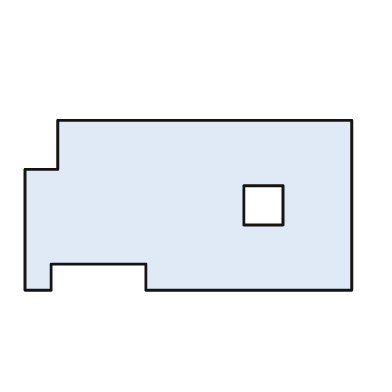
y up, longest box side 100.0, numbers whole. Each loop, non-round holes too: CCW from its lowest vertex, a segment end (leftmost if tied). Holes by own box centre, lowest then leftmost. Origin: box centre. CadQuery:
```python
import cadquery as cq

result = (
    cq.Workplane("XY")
    .moveTo(-50.0, -26.0)
    .lineTo(-42.0, -26.0)
    .lineTo(-42.0, -18.0)
    .lineTo(-13.0, -18.0)
    .lineTo(-13.0, -26.0)
    .lineTo(50.0, -26.0)
    .lineTo(50.0, 26.0)
    .lineTo(-40.0, 26.0)
    .lineTo(-40.0, 11.0)
    .lineTo(-50.0, 11.0)
    .close()
    .moveTo(17.0, -6.0)
    .lineTo(29.0, -6.0)
    .lineTo(29.0, 6.0)
    .lineTo(17.0, 6.0)
    .close()
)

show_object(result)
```